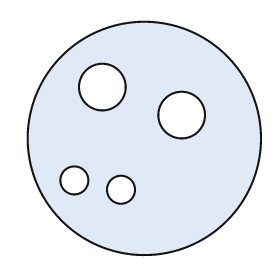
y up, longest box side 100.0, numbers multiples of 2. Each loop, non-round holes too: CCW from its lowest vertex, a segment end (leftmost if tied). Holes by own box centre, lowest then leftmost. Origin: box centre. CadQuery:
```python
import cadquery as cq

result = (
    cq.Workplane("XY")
    .moveTo(0.0, 0.0)
    .circle(50.0)
    .moveTo(-10.0, -22.0)
    .circle(6.0)
    .moveTo(-30.0, -18.0)
    .circle(6.0)
    .moveTo(16.0, 10.0)
    .circle(10.0)
    .moveTo(-18.0, 22.0)
    .circle(10.0)
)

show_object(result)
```